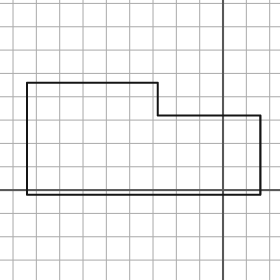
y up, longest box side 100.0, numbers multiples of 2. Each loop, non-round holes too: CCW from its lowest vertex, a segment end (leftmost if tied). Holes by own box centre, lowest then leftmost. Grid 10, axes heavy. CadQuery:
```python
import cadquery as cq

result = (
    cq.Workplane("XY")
    .moveTo(-84.0, -2.0)
    .lineTo(16.0, -2.0)
    .lineTo(16.0, 32.0)
    .lineTo(-28.0, 32.0)
    .lineTo(-28.0, 46.0)
    .lineTo(-84.0, 46.0)
    .close()
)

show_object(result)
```